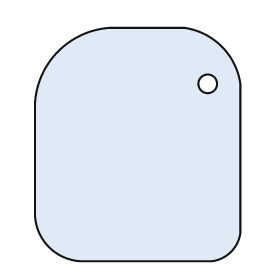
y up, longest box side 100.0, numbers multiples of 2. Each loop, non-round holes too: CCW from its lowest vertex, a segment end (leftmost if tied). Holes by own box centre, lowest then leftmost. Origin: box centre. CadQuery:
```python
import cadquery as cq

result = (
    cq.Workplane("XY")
    .moveTo(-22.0, -50.0)
    .lineTo(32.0, -50.0)
    .threePointArc((40.0, -46.0), (44.0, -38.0))
    .lineTo(44.0, 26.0)
    .threePointArc((36.0, 42.0), (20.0, 50.0))
    .lineTo(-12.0, 50.0)
    .threePointArc((-34.0, 40.0), (-44.0, 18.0))
    .lineTo(-44.0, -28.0)
    .threePointArc((-38.0, -44.0), (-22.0, -50.0))
    .close()
    .moveTo(30.0, 26.0)
    .circle(4.0)
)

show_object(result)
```